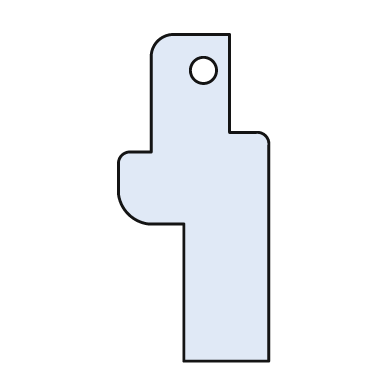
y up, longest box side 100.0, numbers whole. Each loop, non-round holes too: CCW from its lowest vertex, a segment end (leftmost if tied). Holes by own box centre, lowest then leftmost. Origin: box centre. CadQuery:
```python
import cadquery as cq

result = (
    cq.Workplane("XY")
    .moveTo(-3.0, -50.0)
    .lineTo(23.0, -50.0)
    .lineTo(23.0, 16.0)
    .threePointArc((22.0, 19.0), (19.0, 20.0))
    .lineTo(11.0, 20.0)
    .lineTo(11.0, 50.0)
    .lineTo(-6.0, 50.0)
    .threePointArc((-11.0, 48.0), (-13.0, 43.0))
    .lineTo(-13.0, 14.0)
    .lineTo(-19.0, 14.0)
    .threePointArc((-22.0, 13.0), (-23.0, 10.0))
    .lineTo(-23.0, 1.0)
    .threePointArc((-20.0, -5.0), (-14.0, -8.0))
    .lineTo(-3.0, -8.0)
    .close()
    .moveTo(3.0, 39.0)
    .circle(4.0)
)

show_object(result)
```